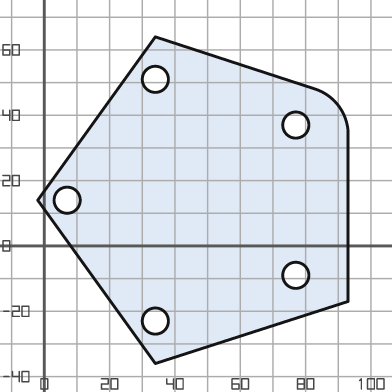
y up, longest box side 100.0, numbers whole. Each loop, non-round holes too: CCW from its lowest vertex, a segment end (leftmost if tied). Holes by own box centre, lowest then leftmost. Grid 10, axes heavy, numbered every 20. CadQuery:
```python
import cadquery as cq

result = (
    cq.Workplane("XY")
    .moveTo(34.0, -36.0)
    .lineTo(93.0, -17.0)
    .lineTo(93.0, 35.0)
    .threePointArc((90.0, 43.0), (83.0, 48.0))
    .lineTo(34.0, 64.0)
    .lineTo(-2.0, 14.0)
    .close()
    .moveTo(34.0, -23.0)
    .circle(4.0)
    .moveTo(77.0, -9.0)
    .circle(4.0)
    .moveTo(7.0, 14.0)
    .circle(4.0)
    .moveTo(77.0, 37.0)
    .circle(4.0)
    .moveTo(34.0, 51.0)
    .circle(4.0)
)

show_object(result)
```